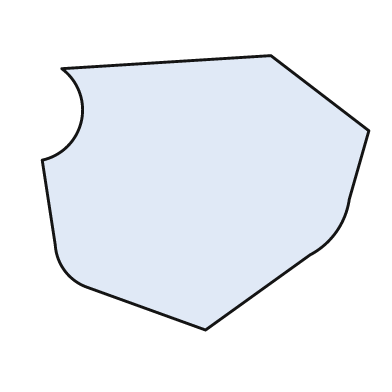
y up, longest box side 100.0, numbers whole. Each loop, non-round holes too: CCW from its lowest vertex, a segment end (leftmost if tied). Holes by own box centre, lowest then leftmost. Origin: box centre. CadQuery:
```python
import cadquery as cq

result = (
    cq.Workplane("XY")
    .moveTo(0.0, -42.0)
    .lineTo(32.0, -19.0)
    .threePointArc((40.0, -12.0), (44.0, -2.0))
    .lineTo(50.0, 19.0)
    .lineTo(20.0, 42.0)
    .lineTo(-44.0, 38.0)
    .threePointArc((-38.0, 22.0), (-50.0, 10.0))
    .lineTo(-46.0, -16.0)
    .threePointArc((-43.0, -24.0), (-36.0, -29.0))
    .close()
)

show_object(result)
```